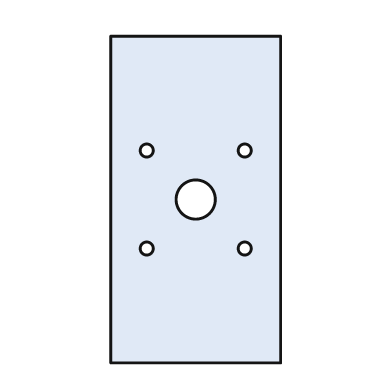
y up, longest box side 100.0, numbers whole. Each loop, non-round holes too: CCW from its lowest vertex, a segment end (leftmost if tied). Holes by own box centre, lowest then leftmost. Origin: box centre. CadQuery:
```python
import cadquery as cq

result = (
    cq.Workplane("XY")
    .moveTo(-26.0, -50.0)
    .lineTo(26.0, -50.0)
    .lineTo(26.0, 50.0)
    .lineTo(-26.0, 50.0)
    .close()
    .moveTo(-15.0, -15.0)
    .circle(2.0)
    .moveTo(15.0, -15.0)
    .circle(2.0)
    .moveTo(0.0, 0.0)
    .circle(6.0)
    .moveTo(-15.0, 15.0)
    .circle(2.0)
    .moveTo(15.0, 15.0)
    .circle(2.0)
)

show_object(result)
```